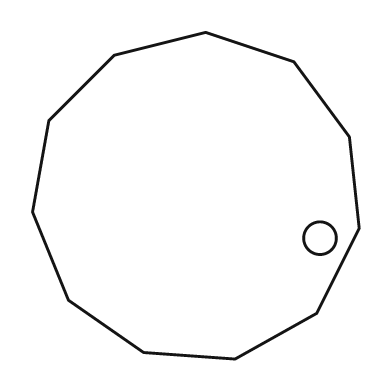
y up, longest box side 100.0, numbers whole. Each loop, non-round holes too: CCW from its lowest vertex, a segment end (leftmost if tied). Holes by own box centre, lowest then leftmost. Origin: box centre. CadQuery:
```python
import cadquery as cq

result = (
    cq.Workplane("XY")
    .moveTo(12.0, -50.0)
    .lineTo(37.0, -36.0)
    .lineTo(50.0, -10.0)
    .lineTo(47.0, 18.0)
    .lineTo(30.0, 41.0)
    .lineTo(3.0, 50.0)
    .lineTo(-25.0, 43.0)
    .lineTo(-45.0, 23.0)
    .lineTo(-50.0, -5.0)
    .lineTo(-39.0, -32.0)
    .lineTo(-16.0, -48.0)
    .close()
    .moveTo(38.0, -13.0)
    .circle(5.0)
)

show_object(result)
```